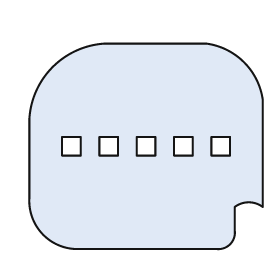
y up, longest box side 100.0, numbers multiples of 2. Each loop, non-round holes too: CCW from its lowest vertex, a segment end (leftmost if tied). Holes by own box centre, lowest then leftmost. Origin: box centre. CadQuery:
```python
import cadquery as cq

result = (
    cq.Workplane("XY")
    .moveTo(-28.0, -44.0)
    .lineTo(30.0, -44.0)
    .threePointArc((36.0, -42.0), (38.0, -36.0))
    .lineTo(38.0, -26.0)
    .threePointArc((44.0, -24.0), (50.0, -26.0))
    .lineTo(50.0, 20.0)
    .threePointArc((42.0, 36.0), (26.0, 44.0))
    .lineTo(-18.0, 44.0)
    .threePointArc((-40.0, 34.0), (-50.0, 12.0))
    .lineTo(-50.0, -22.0)
    .threePointArc((-44.0, -38.0), (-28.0, -44.0))
    .close()
    .moveTo(-36.0, -4.0)
    .lineTo(-28.0, -4.0)
    .lineTo(-28.0, 4.0)
    .lineTo(-36.0, 4.0)
    .close()
    .moveTo(-20.0, -4.0)
    .lineTo(-12.0, -4.0)
    .lineTo(-12.0, 4.0)
    .lineTo(-20.0, 4.0)
    .close()
    .moveTo(-4.0, -4.0)
    .lineTo(4.0, -4.0)
    .lineTo(4.0, 4.0)
    .lineTo(-4.0, 4.0)
    .close()
    .moveTo(12.0, -4.0)
    .lineTo(20.0, -4.0)
    .lineTo(20.0, 4.0)
    .lineTo(12.0, 4.0)
    .close()
    .moveTo(28.0, -4.0)
    .lineTo(36.0, -4.0)
    .lineTo(36.0, 4.0)
    .lineTo(28.0, 4.0)
    .close()
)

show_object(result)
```